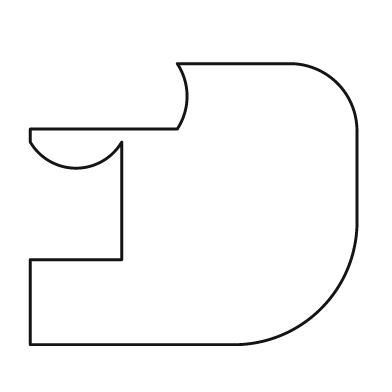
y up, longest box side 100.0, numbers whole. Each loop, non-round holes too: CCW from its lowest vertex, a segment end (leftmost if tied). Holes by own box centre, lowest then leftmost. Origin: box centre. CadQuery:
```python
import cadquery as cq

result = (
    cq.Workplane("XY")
    .moveTo(-50.0, -43.0)
    .lineTo(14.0, -43.0)
    .threePointArc((39.0, -32.0), (50.0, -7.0))
    .lineTo(50.0, 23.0)
    .threePointArc((44.0, 37.0), (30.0, 43.0))
    .lineTo(-5.0, 43.0)
    .threePointArc((-2.0, 33.0), (-5.0, 23.0))
    .lineTo(-50.0, 23.0)
    .lineTo(-50.0, 19.0)
    .threePointArc((-36.0, 11.0), (-22.0, 19.0))
    .lineTo(-22.0, -17.0)
    .lineTo(-50.0, -17.0)
    .close()
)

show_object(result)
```